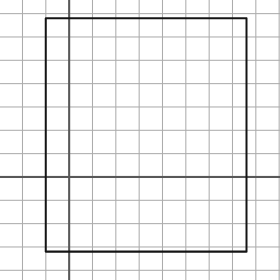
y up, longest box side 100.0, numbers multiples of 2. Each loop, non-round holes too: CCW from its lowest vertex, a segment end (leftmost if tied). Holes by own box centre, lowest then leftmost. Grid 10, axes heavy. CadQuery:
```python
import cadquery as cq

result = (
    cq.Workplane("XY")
    .moveTo(-10.0, -32.0)
    .lineTo(76.0, -32.0)
    .lineTo(76.0, 68.0)
    .lineTo(-10.0, 68.0)
    .close()
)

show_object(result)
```